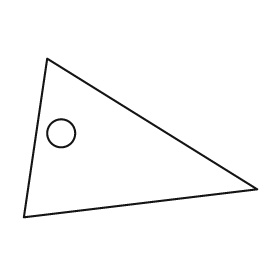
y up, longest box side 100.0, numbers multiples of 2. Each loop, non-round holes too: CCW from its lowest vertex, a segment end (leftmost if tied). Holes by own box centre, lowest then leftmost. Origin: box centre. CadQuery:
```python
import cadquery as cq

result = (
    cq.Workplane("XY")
    .moveTo(-50.0, -34.0)
    .lineTo(50.0, -22.0)
    .lineTo(-40.0, 34.0)
    .close()
    .moveTo(-34.0, 2.0)
    .circle(6.0)
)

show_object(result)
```